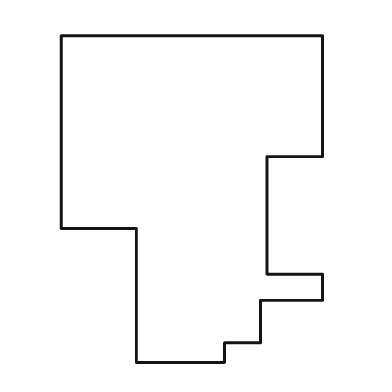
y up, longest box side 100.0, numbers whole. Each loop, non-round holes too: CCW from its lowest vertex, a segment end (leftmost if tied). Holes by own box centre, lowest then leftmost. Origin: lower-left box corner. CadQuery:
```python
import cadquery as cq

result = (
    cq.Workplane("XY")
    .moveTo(23.0, 0.0)
    .lineTo(50.0, 0.0)
    .lineTo(50.0, 6.0)
    .lineTo(61.0, 6.0)
    .lineTo(61.0, 19.0)
    .lineTo(80.0, 19.0)
    .lineTo(80.0, 27.0)
    .lineTo(63.0, 27.0)
    .lineTo(63.0, 63.0)
    .lineTo(80.0, 63.0)
    .lineTo(80.0, 100.0)
    .lineTo(0.0, 100.0)
    .lineTo(0.0, 41.0)
    .lineTo(23.0, 41.0)
    .close()
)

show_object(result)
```